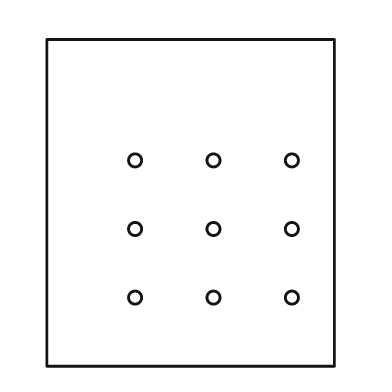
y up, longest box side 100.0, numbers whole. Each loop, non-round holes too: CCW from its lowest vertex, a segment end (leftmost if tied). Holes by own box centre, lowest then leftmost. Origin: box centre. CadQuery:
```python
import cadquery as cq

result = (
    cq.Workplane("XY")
    .moveTo(-44.0, -50.0)
    .lineTo(44.0, -50.0)
    .lineTo(44.0, 50.0)
    .lineTo(-44.0, 50.0)
    .close()
    .moveTo(-17.0, -29.0)
    .circle(2.0)
    .moveTo(7.0, -29.0)
    .circle(2.0)
    .moveTo(31.0, -29.0)
    .circle(2.0)
    .moveTo(-17.0, -8.0)
    .circle(2.0)
    .moveTo(7.0, -8.0)
    .circle(2.0)
    .moveTo(31.0, -8.0)
    .circle(2.0)
    .moveTo(-17.0, 13.0)
    .circle(2.0)
    .moveTo(7.0, 13.0)
    .circle(2.0)
    .moveTo(31.0, 13.0)
    .circle(2.0)
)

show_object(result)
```